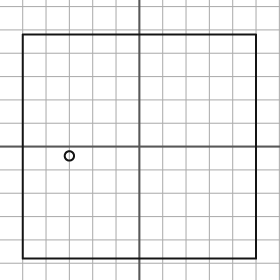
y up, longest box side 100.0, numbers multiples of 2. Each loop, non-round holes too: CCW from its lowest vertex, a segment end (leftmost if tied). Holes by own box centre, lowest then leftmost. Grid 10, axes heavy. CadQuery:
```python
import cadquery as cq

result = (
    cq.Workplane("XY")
    .moveTo(-50.0, -48.0)
    .lineTo(50.0, -48.0)
    .lineTo(50.0, 48.0)
    .lineTo(-50.0, 48.0)
    .close()
    .moveTo(-30.0, -4.0)
    .circle(2.0)
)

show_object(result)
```